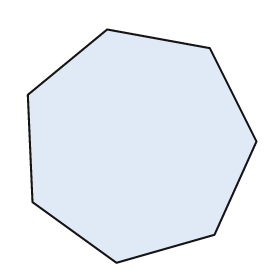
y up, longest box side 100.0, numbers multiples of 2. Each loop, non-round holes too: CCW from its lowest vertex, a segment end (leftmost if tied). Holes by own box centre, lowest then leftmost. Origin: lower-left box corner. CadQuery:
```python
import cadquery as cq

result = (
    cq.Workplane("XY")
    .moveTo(38.0, 0.0)
    .lineTo(80.0, 12.0)
    .lineTo(98.0, 52.0)
    .lineTo(78.0, 92.0)
    .lineTo(34.0, 100.0)
    .lineTo(0.0, 72.0)
    .lineTo(2.0, 26.0)
    .close()
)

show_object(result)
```